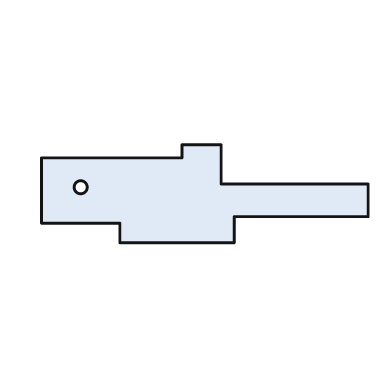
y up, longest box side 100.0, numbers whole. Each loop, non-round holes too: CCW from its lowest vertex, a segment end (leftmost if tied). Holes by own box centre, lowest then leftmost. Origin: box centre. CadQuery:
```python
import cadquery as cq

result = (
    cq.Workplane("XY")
    .moveTo(-26.0, -15.0)
    .lineTo(9.0, -15.0)
    .lineTo(9.0, -7.0)
    .lineTo(50.0, -7.0)
    .lineTo(50.0, 3.0)
    .lineTo(5.0, 3.0)
    .lineTo(5.0, 15.0)
    .lineTo(-7.0, 15.0)
    .lineTo(-7.0, 11.0)
    .lineTo(-50.0, 11.0)
    .lineTo(-50.0, -9.0)
    .lineTo(-26.0, -9.0)
    .close()
    .moveTo(-38.0, 2.0)
    .circle(2.0)
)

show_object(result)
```